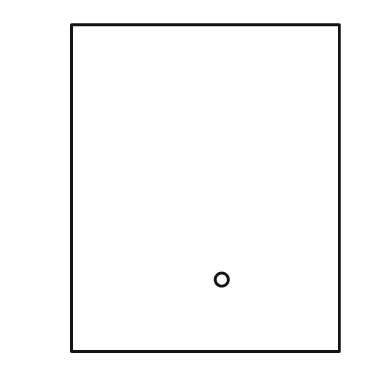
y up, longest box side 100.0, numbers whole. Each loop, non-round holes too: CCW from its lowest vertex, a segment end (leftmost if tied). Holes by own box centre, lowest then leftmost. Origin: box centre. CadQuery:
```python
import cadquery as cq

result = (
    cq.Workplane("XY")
    .moveTo(-41.0, -50.0)
    .lineTo(41.0, -50.0)
    .lineTo(41.0, 50.0)
    .lineTo(-41.0, 50.0)
    .close()
    .moveTo(5.0, -28.0)
    .circle(2.0)
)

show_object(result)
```